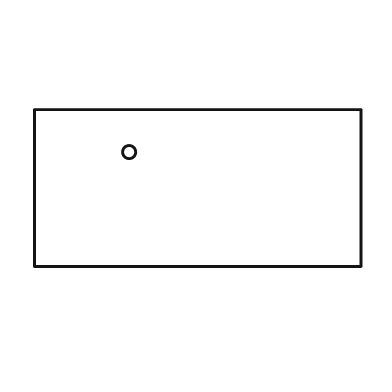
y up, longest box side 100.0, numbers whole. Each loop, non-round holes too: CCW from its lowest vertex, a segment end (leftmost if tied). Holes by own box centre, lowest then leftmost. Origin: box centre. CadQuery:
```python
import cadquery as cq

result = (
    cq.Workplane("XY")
    .moveTo(-50.0, -24.0)
    .lineTo(50.0, -24.0)
    .lineTo(50.0, 24.0)
    .lineTo(-50.0, 24.0)
    .close()
    .moveTo(-21.0, 11.0)
    .circle(2.0)
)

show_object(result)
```